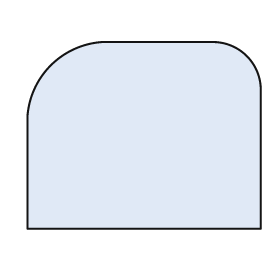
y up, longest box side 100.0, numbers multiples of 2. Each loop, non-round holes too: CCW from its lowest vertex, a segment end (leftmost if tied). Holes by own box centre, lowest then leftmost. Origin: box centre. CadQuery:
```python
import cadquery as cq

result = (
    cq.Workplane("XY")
    .moveTo(-50.0, -40.0)
    .lineTo(50.0, -40.0)
    .lineTo(50.0, 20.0)
    .threePointArc((44.0, 34.0), (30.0, 40.0))
    .lineTo(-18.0, 40.0)
    .threePointArc((-40.0, 30.0), (-50.0, 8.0))
    .close()
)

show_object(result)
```